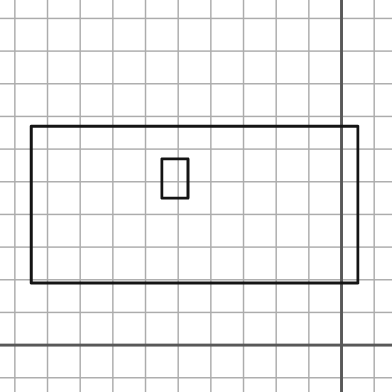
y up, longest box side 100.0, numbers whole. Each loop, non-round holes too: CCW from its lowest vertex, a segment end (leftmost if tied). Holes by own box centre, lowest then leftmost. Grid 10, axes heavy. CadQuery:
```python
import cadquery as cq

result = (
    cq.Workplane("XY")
    .moveTo(-95.0, 19.0)
    .lineTo(5.0, 19.0)
    .lineTo(5.0, 67.0)
    .lineTo(-95.0, 67.0)
    .close()
    .moveTo(-55.0, 45.0)
    .lineTo(-47.0, 45.0)
    .lineTo(-47.0, 57.0)
    .lineTo(-55.0, 57.0)
    .close()
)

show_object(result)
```